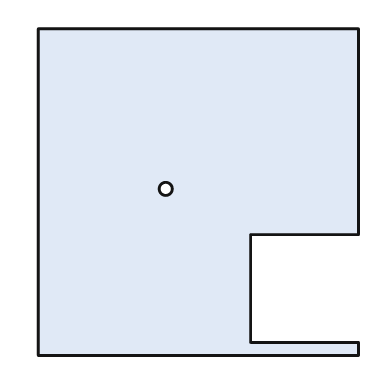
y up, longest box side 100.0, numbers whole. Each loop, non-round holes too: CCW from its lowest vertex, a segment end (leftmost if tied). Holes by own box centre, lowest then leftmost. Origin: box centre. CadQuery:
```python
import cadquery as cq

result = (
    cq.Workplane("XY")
    .moveTo(-49.0, -50.0)
    .lineTo(49.0, -50.0)
    .lineTo(49.0, -46.0)
    .lineTo(16.0, -46.0)
    .lineTo(16.0, -13.0)
    .lineTo(49.0, -13.0)
    .lineTo(49.0, 50.0)
    .lineTo(-49.0, 50.0)
    .close()
    .moveTo(-10.0, 1.0)
    .circle(2.0)
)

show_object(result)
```